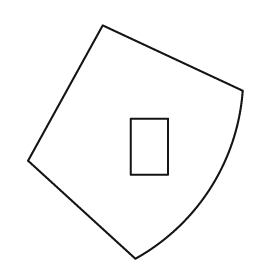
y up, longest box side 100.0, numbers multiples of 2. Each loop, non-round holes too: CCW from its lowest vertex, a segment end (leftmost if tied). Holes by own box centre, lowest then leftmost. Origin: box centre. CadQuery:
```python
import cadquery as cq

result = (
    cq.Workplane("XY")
    .moveTo(0.0, -50.0)
    .threePointArc((32.0, -20.0), (46.0, 22.0))
    .lineTo(-14.0, 50.0)
    .lineTo(-46.0, -8.0)
    .close()
    .moveTo(-2.0, -14.0)
    .lineTo(14.0, -14.0)
    .lineTo(14.0, 10.0)
    .lineTo(-2.0, 10.0)
    .close()
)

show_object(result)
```